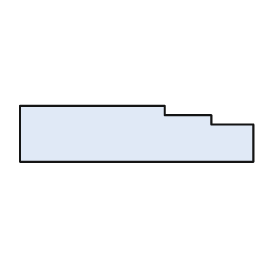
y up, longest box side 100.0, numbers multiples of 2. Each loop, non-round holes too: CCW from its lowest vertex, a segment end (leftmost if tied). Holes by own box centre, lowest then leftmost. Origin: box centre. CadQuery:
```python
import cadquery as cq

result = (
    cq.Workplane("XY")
    .moveTo(-50.0, -12.0)
    .lineTo(50.0, -12.0)
    .lineTo(50.0, 4.0)
    .lineTo(32.0, 4.0)
    .lineTo(32.0, 8.0)
    .lineTo(12.0, 8.0)
    .lineTo(12.0, 12.0)
    .lineTo(-50.0, 12.0)
    .close()
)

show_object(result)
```